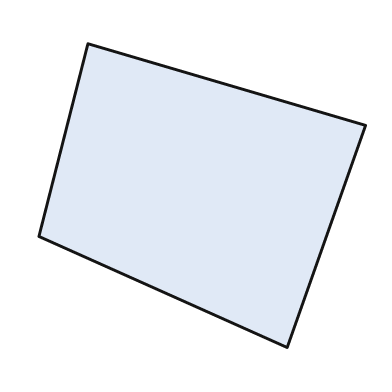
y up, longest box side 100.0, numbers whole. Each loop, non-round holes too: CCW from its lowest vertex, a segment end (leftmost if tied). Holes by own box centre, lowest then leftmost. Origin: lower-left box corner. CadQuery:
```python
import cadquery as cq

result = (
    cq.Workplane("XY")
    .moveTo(76.0, 0.0)
    .lineTo(100.0, 68.0)
    .lineTo(15.0, 93.0)
    .lineTo(0.0, 34.0)
    .close()
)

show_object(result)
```